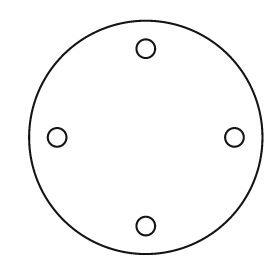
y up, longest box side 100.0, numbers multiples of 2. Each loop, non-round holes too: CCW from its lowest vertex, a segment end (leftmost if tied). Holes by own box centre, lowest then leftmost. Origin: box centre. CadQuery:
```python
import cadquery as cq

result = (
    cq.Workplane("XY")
    .moveTo(0.0, 0.0)
    .circle(50.0)
    .moveTo(0.0, -38.0)
    .circle(4.0)
    .moveTo(-38.0, 0.0)
    .circle(4.0)
    .moveTo(38.0, 0.0)
    .circle(4.0)
    .moveTo(0.0, 38.0)
    .circle(4.0)
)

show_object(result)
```